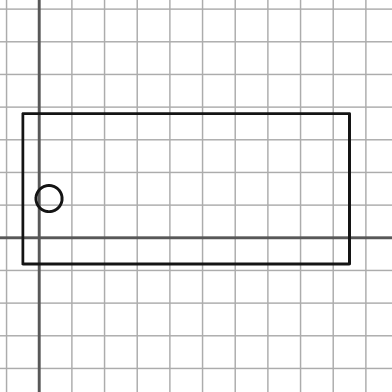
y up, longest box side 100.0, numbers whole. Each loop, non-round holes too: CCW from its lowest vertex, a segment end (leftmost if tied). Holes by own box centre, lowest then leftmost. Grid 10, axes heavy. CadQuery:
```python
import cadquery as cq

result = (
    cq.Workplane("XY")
    .moveTo(-5.0, -8.0)
    .lineTo(95.0, -8.0)
    .lineTo(95.0, 38.0)
    .lineTo(-5.0, 38.0)
    .close()
    .moveTo(3.0, 12.0)
    .circle(4.0)
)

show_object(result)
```